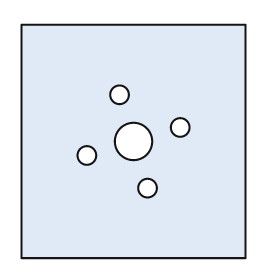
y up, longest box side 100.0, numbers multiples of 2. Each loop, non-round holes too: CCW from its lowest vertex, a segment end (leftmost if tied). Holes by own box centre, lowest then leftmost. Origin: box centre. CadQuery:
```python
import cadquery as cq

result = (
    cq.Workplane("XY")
    .moveTo(-48.0, -50.0)
    .lineTo(48.0, -50.0)
    .lineTo(48.0, 50.0)
    .lineTo(-48.0, 50.0)
    .close()
    .moveTo(6.0, -20.0)
    .circle(4.0)
    .moveTo(-20.0, -6.0)
    .circle(4.0)
    .moveTo(0.0, 0.0)
    .circle(8.0)
    .moveTo(20.0, 6.0)
    .circle(4.0)
    .moveTo(-6.0, 20.0)
    .circle(4.0)
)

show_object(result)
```